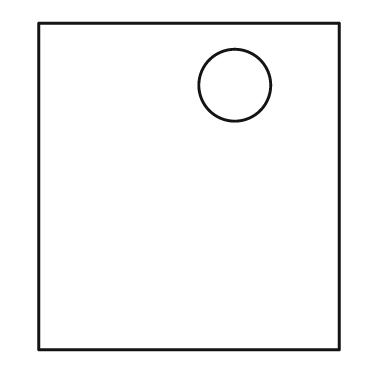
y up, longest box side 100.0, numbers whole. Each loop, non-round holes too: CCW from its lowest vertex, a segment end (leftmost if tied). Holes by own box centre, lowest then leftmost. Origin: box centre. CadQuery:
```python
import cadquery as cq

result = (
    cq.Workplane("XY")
    .moveTo(-46.0, -50.0)
    .lineTo(46.0, -50.0)
    .lineTo(46.0, 50.0)
    .lineTo(-46.0, 50.0)
    .close()
    .moveTo(14.0, 31.0)
    .circle(11.0)
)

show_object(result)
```